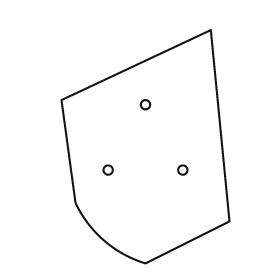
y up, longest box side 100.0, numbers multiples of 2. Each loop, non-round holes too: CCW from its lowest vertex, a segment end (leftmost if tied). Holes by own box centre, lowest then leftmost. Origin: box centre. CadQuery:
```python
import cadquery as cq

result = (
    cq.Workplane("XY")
    .moveTo(0.0, -50.0)
    .lineTo(36.0, -32.0)
    .lineTo(28.0, 50.0)
    .lineTo(-36.0, 20.0)
    .lineTo(-30.0, -24.0)
    .threePointArc((-18.0, -40.0), (0.0, -50.0))
    .close()
    .moveTo(-16.0, -10.0)
    .circle(2.0)
    .moveTo(16.0, -10.0)
    .circle(2.0)
    .moveTo(0.0, 18.0)
    .circle(2.0)
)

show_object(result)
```